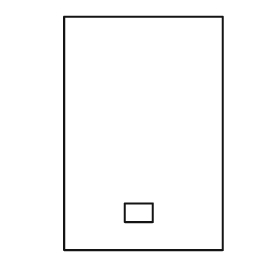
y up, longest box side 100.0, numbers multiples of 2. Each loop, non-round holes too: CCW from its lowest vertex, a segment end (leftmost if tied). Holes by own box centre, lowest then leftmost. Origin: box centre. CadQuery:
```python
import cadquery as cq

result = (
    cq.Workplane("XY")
    .moveTo(-34.0, -50.0)
    .lineTo(34.0, -50.0)
    .lineTo(34.0, 50.0)
    .lineTo(-34.0, 50.0)
    .close()
    .moveTo(-8.0, -38.0)
    .lineTo(4.0, -38.0)
    .lineTo(4.0, -30.0)
    .lineTo(-8.0, -30.0)
    .close()
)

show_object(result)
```